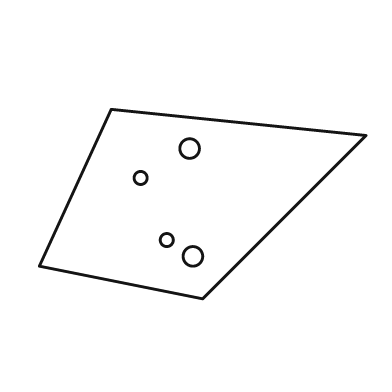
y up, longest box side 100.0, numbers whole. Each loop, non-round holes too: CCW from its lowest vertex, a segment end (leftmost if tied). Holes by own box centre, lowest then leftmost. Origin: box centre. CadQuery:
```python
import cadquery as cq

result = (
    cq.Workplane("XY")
    .moveTo(0.0, -29.0)
    .lineTo(50.0, 21.0)
    .lineTo(-28.0, 29.0)
    .lineTo(-50.0, -19.0)
    .close()
    .moveTo(-3.0, -16.0)
    .circle(3.0)
    .moveTo(-11.0, -11.0)
    .circle(2.0)
    .moveTo(-19.0, 8.0)
    .circle(2.0)
    .moveTo(-4.0, 17.0)
    .circle(3.0)
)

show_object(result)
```